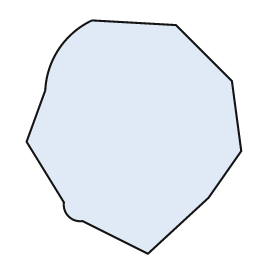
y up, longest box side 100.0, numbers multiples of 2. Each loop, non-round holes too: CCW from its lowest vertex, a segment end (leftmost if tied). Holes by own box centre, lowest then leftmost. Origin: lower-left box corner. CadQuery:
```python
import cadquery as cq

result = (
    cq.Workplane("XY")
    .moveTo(52.0, 0.0)
    .lineTo(78.0, 24.0)
    .lineTo(92.0, 44.0)
    .lineTo(88.0, 74.0)
    .lineTo(64.0, 98.0)
    .lineTo(28.0, 100.0)
    .threePointArc((14.0, 88.0), (8.0, 70.0))
    .lineTo(0.0, 48.0)
    .lineTo(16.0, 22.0)
    .threePointArc((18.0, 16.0), (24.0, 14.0))
    .close()
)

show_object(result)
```